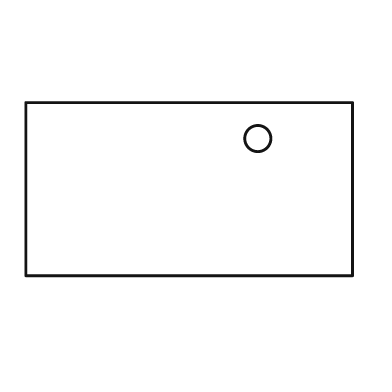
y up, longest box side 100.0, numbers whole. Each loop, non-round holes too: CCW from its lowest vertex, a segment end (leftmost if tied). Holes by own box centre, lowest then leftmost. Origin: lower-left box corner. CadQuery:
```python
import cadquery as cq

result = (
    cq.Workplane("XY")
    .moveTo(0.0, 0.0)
    .lineTo(100.0, 0.0)
    .lineTo(100.0, 53.0)
    .lineTo(0.0, 53.0)
    .close()
    .moveTo(71.0, 42.0)
    .circle(4.0)
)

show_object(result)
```